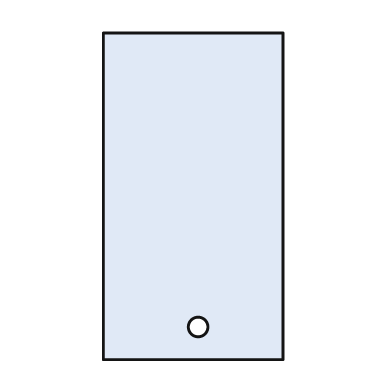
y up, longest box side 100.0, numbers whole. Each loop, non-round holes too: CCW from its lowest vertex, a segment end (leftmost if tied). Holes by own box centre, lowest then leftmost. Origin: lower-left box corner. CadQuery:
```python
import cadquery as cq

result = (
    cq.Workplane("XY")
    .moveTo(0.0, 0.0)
    .lineTo(55.0, 0.0)
    .lineTo(55.0, 100.0)
    .lineTo(0.0, 100.0)
    .close()
    .moveTo(29.0, 10.0)
    .circle(3.0)
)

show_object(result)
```